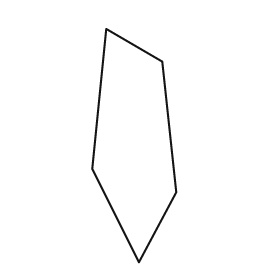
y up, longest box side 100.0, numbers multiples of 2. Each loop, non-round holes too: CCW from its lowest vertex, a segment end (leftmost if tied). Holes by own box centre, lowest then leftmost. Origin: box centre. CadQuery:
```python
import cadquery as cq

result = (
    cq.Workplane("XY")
    .moveTo(2.0, -50.0)
    .lineTo(18.0, -20.0)
    .lineTo(12.0, 36.0)
    .lineTo(-12.0, 50.0)
    .lineTo(-18.0, -10.0)
    .close()
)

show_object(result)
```